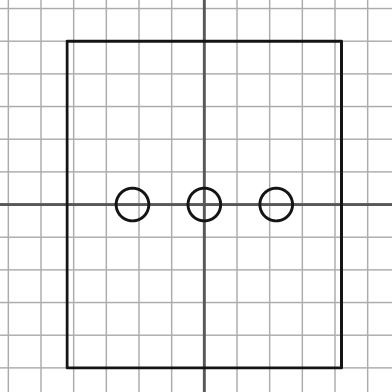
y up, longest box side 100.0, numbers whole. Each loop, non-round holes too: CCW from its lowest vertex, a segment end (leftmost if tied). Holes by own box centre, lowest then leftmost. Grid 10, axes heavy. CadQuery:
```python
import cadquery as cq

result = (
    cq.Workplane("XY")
    .moveTo(-42.0, -50.0)
    .lineTo(42.0, -50.0)
    .lineTo(42.0, 50.0)
    .lineTo(-42.0, 50.0)
    .close()
    .moveTo(-22.0, 0.0)
    .circle(5.0)
    .moveTo(0.0, 0.0)
    .circle(5.0)
    .moveTo(22.0, 0.0)
    .circle(5.0)
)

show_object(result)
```